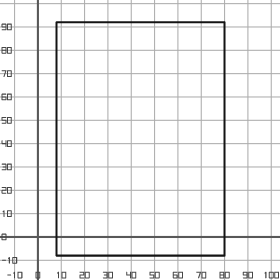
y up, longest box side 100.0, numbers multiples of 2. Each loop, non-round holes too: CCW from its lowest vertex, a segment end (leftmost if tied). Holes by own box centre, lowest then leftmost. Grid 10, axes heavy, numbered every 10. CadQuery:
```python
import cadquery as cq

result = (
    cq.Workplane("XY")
    .moveTo(8.0, -8.0)
    .lineTo(80.0, -8.0)
    .lineTo(80.0, 92.0)
    .lineTo(8.0, 92.0)
    .close()
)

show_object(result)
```